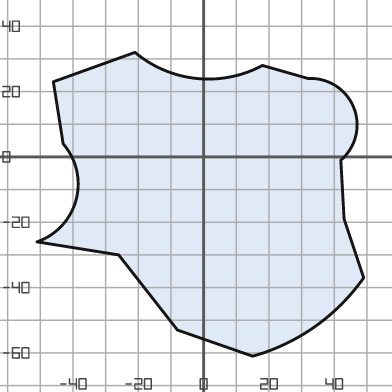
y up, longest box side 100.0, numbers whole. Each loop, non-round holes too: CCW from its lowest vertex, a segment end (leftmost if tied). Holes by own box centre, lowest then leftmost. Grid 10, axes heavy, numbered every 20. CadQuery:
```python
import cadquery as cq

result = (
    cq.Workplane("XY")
    .moveTo(15.0, -61.0)
    .threePointArc((34.0, -52.0), (49.0, -37.0))
    .lineTo(43.0, -19.0)
    .lineTo(42.0, -1.0)
    .threePointArc((46.0, 15.0), (32.0, 24.0))
    .lineTo(18.0, 28.0)
    .threePointArc((-2.0, 24.0), (-21.0, 32.0))
    .lineTo(-46.0, 23.0)
    .lineTo(-43.0, 4.0)
    .threePointArc((-39.0, -13.0), (-51.0, -26.0))
    .lineTo(-26.0, -30.0)
    .lineTo(-8.0, -53.0)
    .close()
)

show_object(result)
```